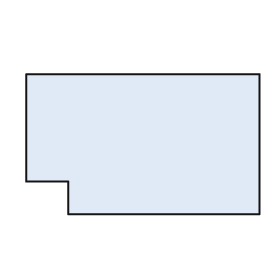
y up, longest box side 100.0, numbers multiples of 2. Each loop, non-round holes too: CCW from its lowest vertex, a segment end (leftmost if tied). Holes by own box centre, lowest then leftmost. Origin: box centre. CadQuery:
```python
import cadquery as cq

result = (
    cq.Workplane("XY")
    .moveTo(-32.0, -30.0)
    .lineTo(50.0, -30.0)
    .lineTo(50.0, 30.0)
    .lineTo(-50.0, 30.0)
    .lineTo(-50.0, -16.0)
    .lineTo(-32.0, -16.0)
    .close()
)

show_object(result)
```